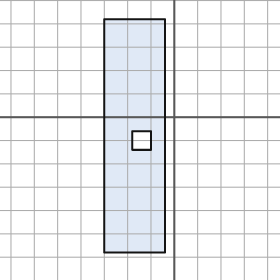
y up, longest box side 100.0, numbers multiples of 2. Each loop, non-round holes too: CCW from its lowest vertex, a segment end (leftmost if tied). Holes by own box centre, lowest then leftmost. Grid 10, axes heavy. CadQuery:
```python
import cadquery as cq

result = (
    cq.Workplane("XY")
    .moveTo(-30.0, -58.0)
    .lineTo(-4.0, -58.0)
    .lineTo(-4.0, 42.0)
    .lineTo(-30.0, 42.0)
    .close()
    .moveTo(-18.0, -14.0)
    .lineTo(-10.0, -14.0)
    .lineTo(-10.0, -6.0)
    .lineTo(-18.0, -6.0)
    .close()
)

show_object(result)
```